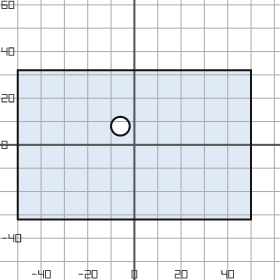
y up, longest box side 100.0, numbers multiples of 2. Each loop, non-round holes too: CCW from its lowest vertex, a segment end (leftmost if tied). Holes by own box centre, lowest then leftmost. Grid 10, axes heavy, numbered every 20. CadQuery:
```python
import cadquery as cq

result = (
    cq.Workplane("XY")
    .moveTo(-50.0, -32.0)
    .lineTo(50.0, -32.0)
    .lineTo(50.0, 32.0)
    .lineTo(-50.0, 32.0)
    .close()
    .moveTo(-6.0, 8.0)
    .circle(4.0)
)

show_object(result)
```